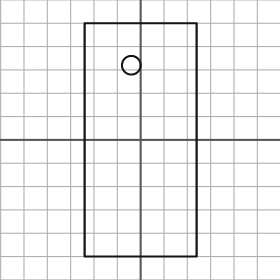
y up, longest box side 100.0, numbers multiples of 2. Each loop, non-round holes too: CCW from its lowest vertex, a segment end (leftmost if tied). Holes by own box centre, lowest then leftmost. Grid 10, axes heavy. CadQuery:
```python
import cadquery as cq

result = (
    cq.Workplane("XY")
    .moveTo(-24.0, -50.0)
    .lineTo(24.0, -50.0)
    .lineTo(24.0, 50.0)
    .lineTo(-24.0, 50.0)
    .close()
    .moveTo(-4.0, 32.0)
    .circle(4.0)
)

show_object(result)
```